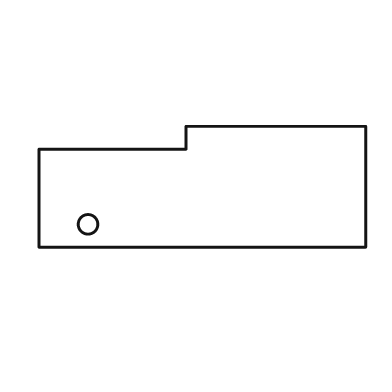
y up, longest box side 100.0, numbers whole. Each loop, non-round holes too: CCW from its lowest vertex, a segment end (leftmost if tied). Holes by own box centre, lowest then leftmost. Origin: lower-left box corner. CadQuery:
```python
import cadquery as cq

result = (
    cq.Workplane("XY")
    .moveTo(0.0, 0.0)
    .lineTo(100.0, 0.0)
    .lineTo(100.0, 37.0)
    .lineTo(45.0, 37.0)
    .lineTo(45.0, 30.0)
    .lineTo(0.0, 30.0)
    .close()
    .moveTo(15.0, 7.0)
    .circle(3.0)
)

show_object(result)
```